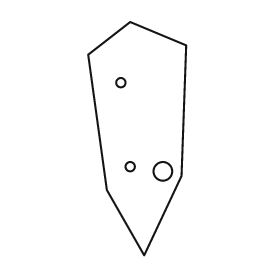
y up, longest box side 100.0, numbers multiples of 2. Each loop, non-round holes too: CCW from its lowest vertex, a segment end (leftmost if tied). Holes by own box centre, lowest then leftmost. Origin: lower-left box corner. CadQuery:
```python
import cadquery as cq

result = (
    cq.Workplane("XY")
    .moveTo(24.0, 0.0)
    .lineTo(40.0, 34.0)
    .lineTo(42.0, 90.0)
    .lineTo(18.0, 100.0)
    .lineTo(0.0, 86.0)
    .lineTo(8.0, 28.0)
    .close()
    .moveTo(32.0, 36.0)
    .circle(4.0)
    .moveTo(18.0, 38.0)
    .circle(2.0)
    .moveTo(14.0, 74.0)
    .circle(2.0)
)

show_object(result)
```